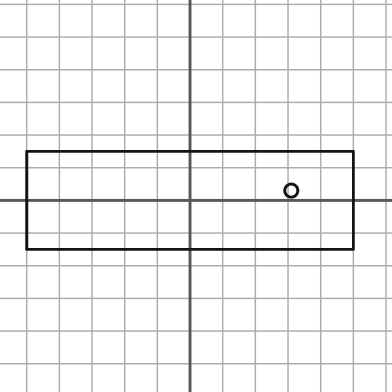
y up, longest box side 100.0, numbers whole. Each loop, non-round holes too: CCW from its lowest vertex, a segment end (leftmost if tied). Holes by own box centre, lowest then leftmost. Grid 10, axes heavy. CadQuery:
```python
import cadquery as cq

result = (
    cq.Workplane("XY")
    .moveTo(-50.0, -15.0)
    .lineTo(50.0, -15.0)
    .lineTo(50.0, 15.0)
    .lineTo(-50.0, 15.0)
    .close()
    .moveTo(31.0, 3.0)
    .circle(2.0)
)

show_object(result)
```